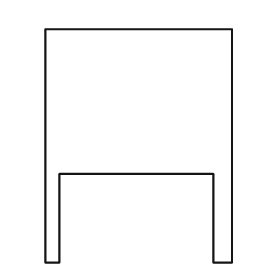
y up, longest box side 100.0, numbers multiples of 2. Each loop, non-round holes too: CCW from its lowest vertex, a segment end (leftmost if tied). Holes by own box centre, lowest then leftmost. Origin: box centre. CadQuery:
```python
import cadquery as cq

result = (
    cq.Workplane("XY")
    .moveTo(-40.0, -50.0)
    .lineTo(-34.0, -50.0)
    .lineTo(-34.0, -12.0)
    .lineTo(32.0, -12.0)
    .lineTo(32.0, -50.0)
    .lineTo(40.0, -50.0)
    .lineTo(40.0, 50.0)
    .lineTo(-40.0, 50.0)
    .close()
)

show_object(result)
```